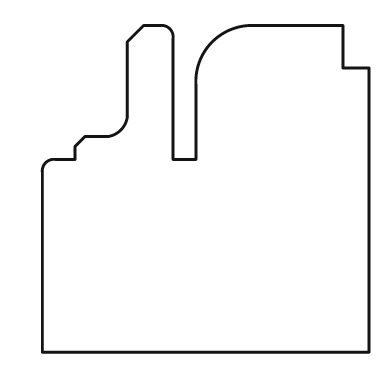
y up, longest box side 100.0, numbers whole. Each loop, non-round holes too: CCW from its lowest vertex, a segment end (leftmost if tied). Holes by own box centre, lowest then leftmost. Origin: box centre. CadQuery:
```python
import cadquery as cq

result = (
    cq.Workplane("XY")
    .moveTo(-50.0, -50.0)
    .lineTo(50.0, -50.0)
    .lineTo(50.0, 37.0)
    .lineTo(42.0, 37.0)
    .lineTo(42.0, 50.0)
    .lineTo(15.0, 50.0)
    .threePointArc((2.0, 45.0), (-3.0, 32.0))
    .lineTo(-3.0, 9.0)
    .lineTo(-10.0, 9.0)
    .lineTo(-10.0, 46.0)
    .threePointArc((-11.0, 49.0), (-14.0, 50.0))
    .lineTo(-19.0, 50.0)
    .lineTo(-24.0, 45.0)
    .lineTo(-24.0, 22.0)
    .threePointArc((-26.0, 18.0), (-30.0, 16.0))
    .lineTo(-37.0, 16.0)
    .lineTo(-40.0, 13.0)
    .lineTo(-40.0, 9.0)
    .lineTo(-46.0, 9.0)
    .threePointArc((-49.0, 8.0), (-50.0, 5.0))
    .close()
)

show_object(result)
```